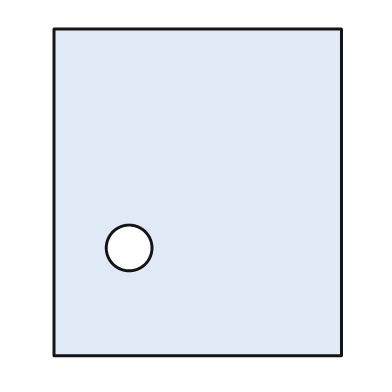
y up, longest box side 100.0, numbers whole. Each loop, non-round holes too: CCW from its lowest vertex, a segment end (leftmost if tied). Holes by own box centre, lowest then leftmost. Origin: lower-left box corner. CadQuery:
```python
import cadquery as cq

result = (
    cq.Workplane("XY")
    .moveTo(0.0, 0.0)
    .lineTo(88.0, 0.0)
    .lineTo(88.0, 100.0)
    .lineTo(0.0, 100.0)
    .close()
    .moveTo(23.0, 33.0)
    .circle(7.0)
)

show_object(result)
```